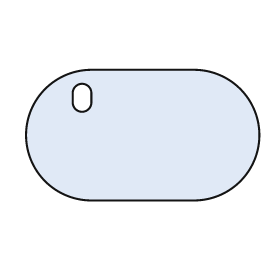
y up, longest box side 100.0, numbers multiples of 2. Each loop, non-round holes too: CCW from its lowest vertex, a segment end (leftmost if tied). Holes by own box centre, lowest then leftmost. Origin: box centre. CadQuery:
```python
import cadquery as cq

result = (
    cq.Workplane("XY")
    .moveTo(-22.0, -28.0)
    .lineTo(22.0, -28.0)
    .threePointArc((50.0, 0.0), (22.0, 28.0))
    .lineTo(-22.0, 28.0)
    .threePointArc((-50.0, 0.0), (-22.0, -28.0))
    .close()
    .moveTo(-30.0, 14.0)
    .threePointArc((-26.0, 10.0), (-22.0, 14.0))
    .lineTo(-22.0, 18.0)
    .threePointArc((-26.0, 22.0), (-30.0, 18.0))
    .close()
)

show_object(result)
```